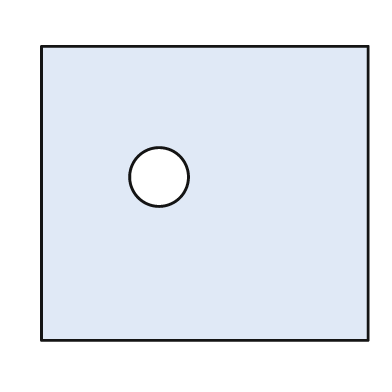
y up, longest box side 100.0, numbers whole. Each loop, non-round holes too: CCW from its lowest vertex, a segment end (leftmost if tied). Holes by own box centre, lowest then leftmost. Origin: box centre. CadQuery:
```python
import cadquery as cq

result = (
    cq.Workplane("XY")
    .moveTo(-50.0, -45.0)
    .lineTo(50.0, -45.0)
    .lineTo(50.0, 45.0)
    .lineTo(-50.0, 45.0)
    .close()
    .moveTo(-14.0, 5.0)
    .circle(9.0)
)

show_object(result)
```